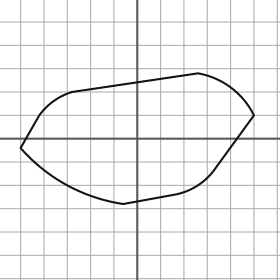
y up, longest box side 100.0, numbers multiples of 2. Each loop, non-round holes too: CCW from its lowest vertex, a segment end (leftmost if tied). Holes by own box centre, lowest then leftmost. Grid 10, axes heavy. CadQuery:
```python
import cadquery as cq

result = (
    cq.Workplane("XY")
    .moveTo(-6.0, -28.0)
    .lineTo(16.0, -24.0)
    .threePointArc((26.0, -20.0), (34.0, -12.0))
    .lineTo(50.0, 10.0)
    .threePointArc((40.0, 22.0), (26.0, 28.0))
    .lineTo(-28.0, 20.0)
    .threePointArc((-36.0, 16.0), (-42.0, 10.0))
    .lineTo(-50.0, -4.0)
    .threePointArc((-30.0, -20.0), (-6.0, -28.0))
    .close()
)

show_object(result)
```